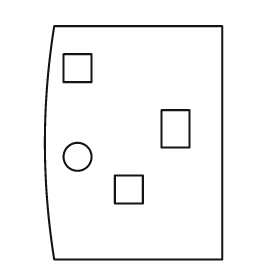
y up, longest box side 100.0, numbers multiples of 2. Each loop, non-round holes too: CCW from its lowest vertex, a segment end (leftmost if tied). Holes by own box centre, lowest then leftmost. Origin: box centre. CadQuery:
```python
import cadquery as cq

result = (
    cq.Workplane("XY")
    .moveTo(-34.0, -50.0)
    .lineTo(38.0, -50.0)
    .lineTo(38.0, 50.0)
    .lineTo(-34.0, 50.0)
    .threePointArc((-38.0, 0.0), (-34.0, -50.0))
    .close()
    .moveTo(-8.0, -26.0)
    .lineTo(4.0, -26.0)
    .lineTo(4.0, -14.0)
    .lineTo(-8.0, -14.0)
    .close()
    .moveTo(-24.0, -6.0)
    .circle(6.0)
    .moveTo(12.0, -2.0)
    .lineTo(24.0, -2.0)
    .lineTo(24.0, 14.0)
    .lineTo(12.0, 14.0)
    .close()
    .moveTo(-30.0, 26.0)
    .lineTo(-18.0, 26.0)
    .lineTo(-18.0, 38.0)
    .lineTo(-30.0, 38.0)
    .close()
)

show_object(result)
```